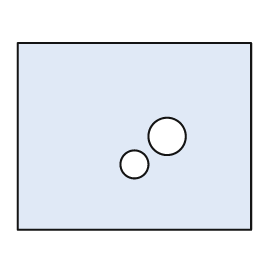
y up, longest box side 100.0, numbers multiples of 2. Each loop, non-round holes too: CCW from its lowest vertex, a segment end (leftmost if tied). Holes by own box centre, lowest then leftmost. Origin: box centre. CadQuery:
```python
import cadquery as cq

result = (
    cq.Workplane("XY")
    .moveTo(-50.0, -40.0)
    .lineTo(50.0, -40.0)
    .lineTo(50.0, 40.0)
    .lineTo(-50.0, 40.0)
    .close()
    .moveTo(0.0, -12.0)
    .circle(6.0)
    .moveTo(14.0, 0.0)
    .circle(8.0)
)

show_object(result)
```